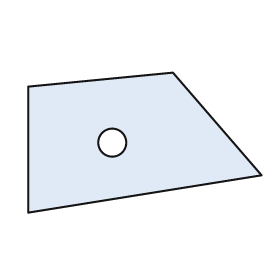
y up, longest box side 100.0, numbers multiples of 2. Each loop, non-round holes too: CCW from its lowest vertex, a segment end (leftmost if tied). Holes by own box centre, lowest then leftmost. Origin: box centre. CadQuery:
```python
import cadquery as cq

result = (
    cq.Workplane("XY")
    .moveTo(-50.0, -30.0)
    .lineTo(50.0, -14.0)
    .lineTo(12.0, 30.0)
    .lineTo(-50.0, 24.0)
    .close()
    .moveTo(-14.0, 0.0)
    .circle(6.0)
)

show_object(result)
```